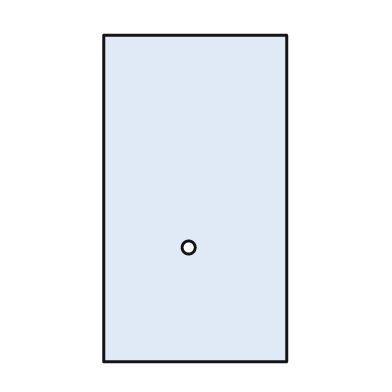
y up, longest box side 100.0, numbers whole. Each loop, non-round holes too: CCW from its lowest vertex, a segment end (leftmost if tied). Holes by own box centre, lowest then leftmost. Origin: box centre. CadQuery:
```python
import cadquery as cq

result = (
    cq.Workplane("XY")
    .moveTo(-28.0, -50.0)
    .lineTo(28.0, -50.0)
    .lineTo(28.0, 50.0)
    .lineTo(-28.0, 50.0)
    .close()
    .moveTo(-2.0, -15.0)
    .circle(2.0)
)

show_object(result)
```